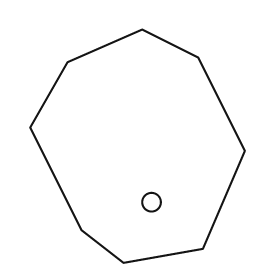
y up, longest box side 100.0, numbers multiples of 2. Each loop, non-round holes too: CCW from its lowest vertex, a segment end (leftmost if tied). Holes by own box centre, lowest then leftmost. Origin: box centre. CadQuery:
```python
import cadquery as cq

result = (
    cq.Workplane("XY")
    .moveTo(-6.0, -50.0)
    .lineTo(28.0, -44.0)
    .lineTo(46.0, -2.0)
    .lineTo(26.0, 38.0)
    .lineTo(2.0, 50.0)
    .lineTo(-30.0, 36.0)
    .lineTo(-46.0, 8.0)
    .lineTo(-24.0, -36.0)
    .close()
    .moveTo(6.0, -24.0)
    .circle(4.0)
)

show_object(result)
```